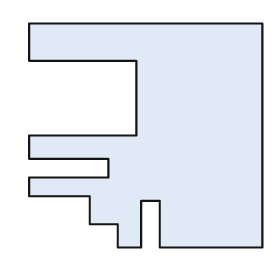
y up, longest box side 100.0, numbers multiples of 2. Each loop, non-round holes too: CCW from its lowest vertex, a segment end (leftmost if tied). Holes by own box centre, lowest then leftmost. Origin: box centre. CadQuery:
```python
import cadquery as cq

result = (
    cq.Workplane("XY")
    .moveTo(-12.0, -48.0)
    .lineTo(-2.0, -48.0)
    .lineTo(-2.0, -28.0)
    .lineTo(6.0, -28.0)
    .lineTo(6.0, -48.0)
    .lineTo(50.0, -48.0)
    .lineTo(50.0, 48.0)
    .lineTo(-50.0, 48.0)
    .lineTo(-50.0, 32.0)
    .lineTo(-4.0, 32.0)
    .lineTo(-4.0, 0.0)
    .lineTo(-50.0, 0.0)
    .lineTo(-50.0, -10.0)
    .lineTo(-16.0, -10.0)
    .lineTo(-16.0, -18.0)
    .lineTo(-50.0, -18.0)
    .lineTo(-50.0, -26.0)
    .lineTo(-24.0, -26.0)
    .lineTo(-24.0, -38.0)
    .lineTo(-12.0, -38.0)
    .close()
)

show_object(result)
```